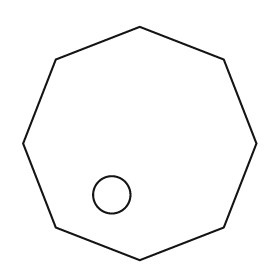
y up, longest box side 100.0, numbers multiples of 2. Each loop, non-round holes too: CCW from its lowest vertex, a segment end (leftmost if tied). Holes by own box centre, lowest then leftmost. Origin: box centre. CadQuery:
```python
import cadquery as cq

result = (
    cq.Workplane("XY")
    .moveTo(0.0, -50.0)
    .lineTo(36.0, -36.0)
    .lineTo(50.0, 0.0)
    .lineTo(36.0, 36.0)
    .lineTo(0.0, 50.0)
    .lineTo(-36.0, 36.0)
    .lineTo(-50.0, 0.0)
    .lineTo(-36.0, -36.0)
    .close()
    .moveTo(-12.0, -22.0)
    .circle(8.0)
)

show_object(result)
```